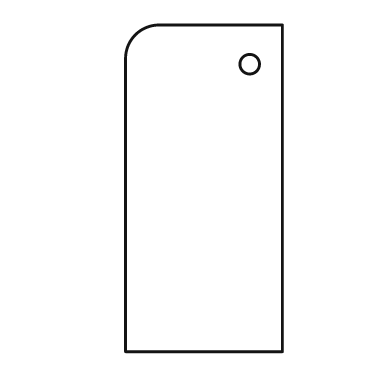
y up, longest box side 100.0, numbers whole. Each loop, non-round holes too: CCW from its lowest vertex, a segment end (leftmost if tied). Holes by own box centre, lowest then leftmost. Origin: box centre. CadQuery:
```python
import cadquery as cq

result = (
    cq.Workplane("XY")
    .moveTo(-24.0, -50.0)
    .lineTo(24.0, -50.0)
    .lineTo(24.0, 50.0)
    .lineTo(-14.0, 50.0)
    .threePointArc((-21.0, 47.0), (-24.0, 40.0))
    .close()
    .moveTo(14.0, 38.0)
    .circle(3.0)
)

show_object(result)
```